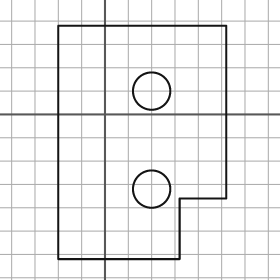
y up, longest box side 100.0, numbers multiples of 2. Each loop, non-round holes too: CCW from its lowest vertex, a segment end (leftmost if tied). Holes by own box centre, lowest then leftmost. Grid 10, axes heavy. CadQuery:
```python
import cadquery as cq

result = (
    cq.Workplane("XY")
    .moveTo(-20.0, -62.0)
    .lineTo(32.0, -62.0)
    .lineTo(32.0, -36.0)
    .lineTo(52.0, -36.0)
    .lineTo(52.0, 38.0)
    .lineTo(-20.0, 38.0)
    .close()
    .moveTo(20.0, -32.0)
    .circle(8.0)
    .moveTo(20.0, 10.0)
    .circle(8.0)
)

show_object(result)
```